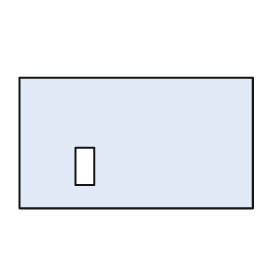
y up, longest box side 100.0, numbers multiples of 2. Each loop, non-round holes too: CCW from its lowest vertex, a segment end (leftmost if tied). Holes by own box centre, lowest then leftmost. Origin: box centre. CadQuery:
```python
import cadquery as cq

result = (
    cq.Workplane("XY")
    .moveTo(-50.0, -28.0)
    .lineTo(50.0, -28.0)
    .lineTo(50.0, 28.0)
    .lineTo(-50.0, 28.0)
    .close()
    .moveTo(-26.0, -18.0)
    .lineTo(-18.0, -18.0)
    .lineTo(-18.0, -2.0)
    .lineTo(-26.0, -2.0)
    .close()
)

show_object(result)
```